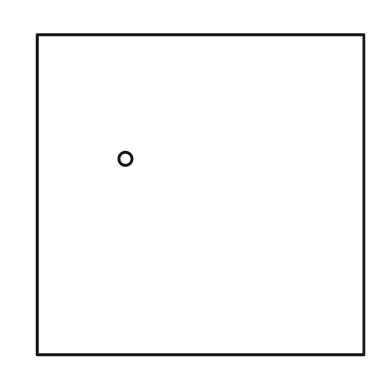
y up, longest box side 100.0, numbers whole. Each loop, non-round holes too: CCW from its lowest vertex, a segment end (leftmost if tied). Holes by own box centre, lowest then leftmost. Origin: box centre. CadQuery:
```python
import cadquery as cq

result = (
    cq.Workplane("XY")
    .moveTo(-50.0, -49.0)
    .lineTo(50.0, -49.0)
    .lineTo(50.0, 49.0)
    .lineTo(-50.0, 49.0)
    .close()
    .moveTo(-23.0, 11.0)
    .circle(2.0)
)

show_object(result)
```